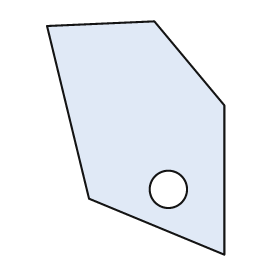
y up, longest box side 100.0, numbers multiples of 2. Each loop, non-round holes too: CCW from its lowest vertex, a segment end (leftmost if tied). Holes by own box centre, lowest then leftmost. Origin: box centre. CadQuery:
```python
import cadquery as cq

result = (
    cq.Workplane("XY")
    .moveTo(38.0, -50.0)
    .lineTo(38.0, 14.0)
    .lineTo(8.0, 50.0)
    .lineTo(-38.0, 48.0)
    .lineTo(-20.0, -26.0)
    .close()
    .moveTo(14.0, -22.0)
    .circle(8.0)
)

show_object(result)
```